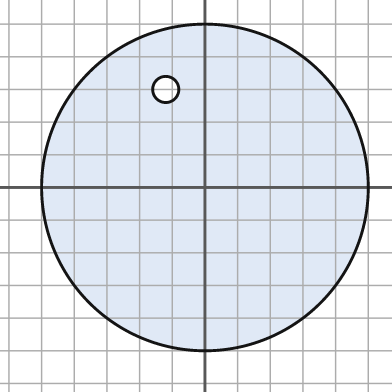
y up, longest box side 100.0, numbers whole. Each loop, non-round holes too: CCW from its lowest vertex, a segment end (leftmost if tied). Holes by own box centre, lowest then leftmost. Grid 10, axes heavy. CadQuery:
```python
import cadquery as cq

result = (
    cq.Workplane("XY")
    .moveTo(0.0, 0.0)
    .circle(50.0)
    .moveTo(-12.0, 30.0)
    .circle(4.0)
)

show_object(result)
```